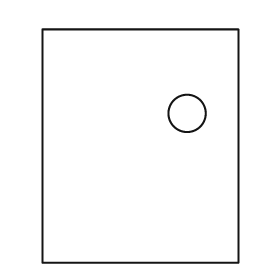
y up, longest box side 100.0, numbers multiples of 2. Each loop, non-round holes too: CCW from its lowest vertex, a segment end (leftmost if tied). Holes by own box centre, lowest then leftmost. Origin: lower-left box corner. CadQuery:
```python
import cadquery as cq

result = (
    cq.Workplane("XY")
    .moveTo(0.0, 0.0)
    .lineTo(84.0, 0.0)
    .lineTo(84.0, 100.0)
    .lineTo(0.0, 100.0)
    .close()
    .moveTo(62.0, 64.0)
    .circle(8.0)
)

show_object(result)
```